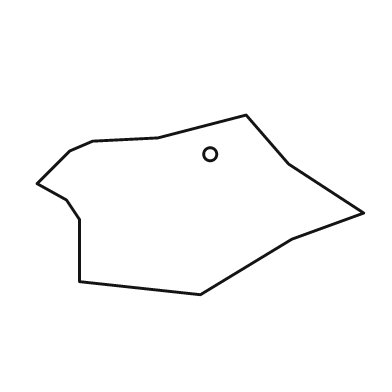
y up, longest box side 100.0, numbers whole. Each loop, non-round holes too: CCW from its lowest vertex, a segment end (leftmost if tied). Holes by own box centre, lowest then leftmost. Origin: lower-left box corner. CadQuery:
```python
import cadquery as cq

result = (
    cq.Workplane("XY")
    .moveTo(50.0, 0.0)
    .lineTo(78.0, 17.0)
    .lineTo(100.0, 25.0)
    .lineTo(77.0, 40.0)
    .lineTo(64.0, 55.0)
    .lineTo(37.0, 48.0)
    .lineTo(17.0, 47.0)
    .lineTo(10.0, 44.0)
    .lineTo(0.0, 34.0)
    .lineTo(9.0, 29.0)
    .lineTo(13.0, 23.0)
    .lineTo(13.0, 4.0)
    .close()
    .moveTo(53.0, 43.0)
    .circle(2.0)
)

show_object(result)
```